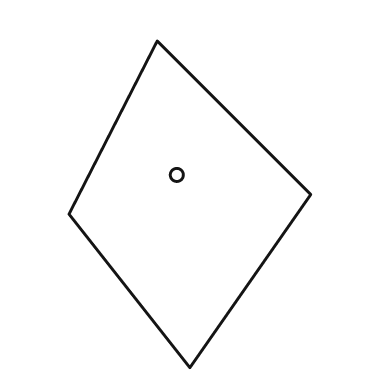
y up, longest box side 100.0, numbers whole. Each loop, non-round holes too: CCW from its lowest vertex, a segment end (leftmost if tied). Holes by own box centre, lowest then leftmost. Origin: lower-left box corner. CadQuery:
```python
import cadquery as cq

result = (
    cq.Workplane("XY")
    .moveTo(37.0, 0.0)
    .lineTo(74.0, 53.0)
    .lineTo(27.0, 100.0)
    .lineTo(0.0, 47.0)
    .close()
    .moveTo(33.0, 59.0)
    .circle(2.0)
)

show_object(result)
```